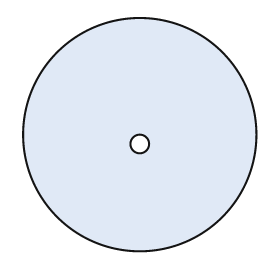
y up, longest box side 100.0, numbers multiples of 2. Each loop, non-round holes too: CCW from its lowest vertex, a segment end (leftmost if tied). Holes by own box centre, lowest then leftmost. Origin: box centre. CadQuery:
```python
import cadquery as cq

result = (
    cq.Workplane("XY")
    .moveTo(0.0, 0.0)
    .circle(50.0)
    .moveTo(0.0, -4.0)
    .circle(4.0)
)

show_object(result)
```